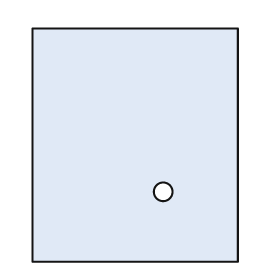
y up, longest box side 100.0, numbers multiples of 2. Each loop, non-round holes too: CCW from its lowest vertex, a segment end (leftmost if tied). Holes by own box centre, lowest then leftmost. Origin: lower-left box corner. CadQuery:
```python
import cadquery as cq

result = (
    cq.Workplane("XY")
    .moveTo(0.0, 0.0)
    .lineTo(88.0, 0.0)
    .lineTo(88.0, 100.0)
    .lineTo(0.0, 100.0)
    .close()
    .moveTo(56.0, 30.0)
    .circle(4.0)
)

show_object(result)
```